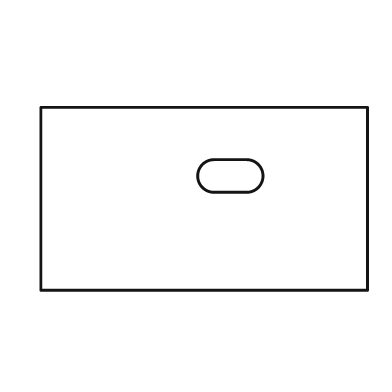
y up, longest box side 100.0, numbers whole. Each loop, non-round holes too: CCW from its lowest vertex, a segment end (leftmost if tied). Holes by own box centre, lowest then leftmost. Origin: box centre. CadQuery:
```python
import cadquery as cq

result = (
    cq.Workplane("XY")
    .moveTo(-50.0, -28.0)
    .lineTo(50.0, -28.0)
    .lineTo(50.0, 28.0)
    .lineTo(-50.0, 28.0)
    .close()
    .moveTo(3.0, 2.0)
    .lineTo(13.0, 2.0)
    .threePointArc((18.0, 7.0), (13.0, 12.0))
    .lineTo(3.0, 12.0)
    .threePointArc((-2.0, 7.0), (3.0, 2.0))
    .close()
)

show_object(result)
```